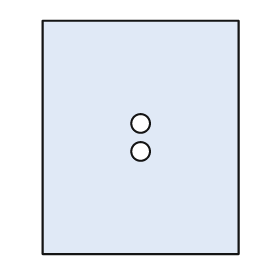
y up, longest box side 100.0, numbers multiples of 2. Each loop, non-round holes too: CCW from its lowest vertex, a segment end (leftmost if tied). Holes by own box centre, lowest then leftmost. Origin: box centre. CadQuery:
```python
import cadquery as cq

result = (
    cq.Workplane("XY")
    .moveTo(-42.0, -50.0)
    .lineTo(42.0, -50.0)
    .lineTo(42.0, 50.0)
    .lineTo(-42.0, 50.0)
    .close()
    .moveTo(0.0, -6.0)
    .circle(4.0)
    .moveTo(0.0, 6.0)
    .circle(4.0)
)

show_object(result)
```